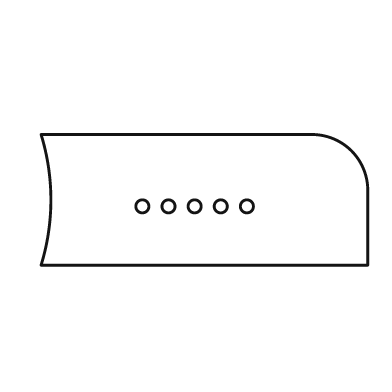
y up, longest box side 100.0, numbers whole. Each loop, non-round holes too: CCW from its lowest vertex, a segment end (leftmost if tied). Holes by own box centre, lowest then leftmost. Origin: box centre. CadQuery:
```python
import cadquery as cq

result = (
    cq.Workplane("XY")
    .moveTo(-50.0, -20.0)
    .lineTo(50.0, -20.0)
    .lineTo(50.0, 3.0)
    .threePointArc((45.0, 15.0), (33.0, 20.0))
    .lineTo(-50.0, 20.0)
    .threePointArc((-47.0, 0.0), (-50.0, -20.0))
    .close()
    .moveTo(-19.0, -2.0)
    .circle(2.0)
    .moveTo(-11.0, -2.0)
    .circle(2.0)
    .moveTo(-3.0, -2.0)
    .circle(2.0)
    .moveTo(5.0, -2.0)
    .circle(2.0)
    .moveTo(13.0, -2.0)
    .circle(2.0)
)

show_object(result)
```